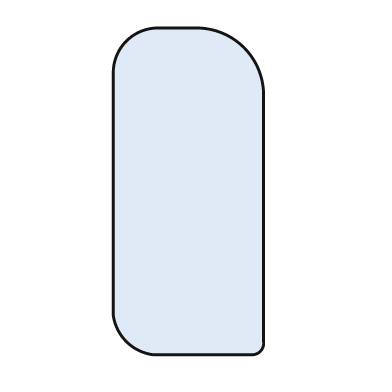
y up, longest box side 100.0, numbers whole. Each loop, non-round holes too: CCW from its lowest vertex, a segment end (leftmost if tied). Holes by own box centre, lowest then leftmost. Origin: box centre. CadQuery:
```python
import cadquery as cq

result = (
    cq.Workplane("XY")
    .moveTo(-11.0, -50.0)
    .lineTo(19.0, -50.0)
    .threePointArc((22.0, -49.0), (23.0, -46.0))
    .lineTo(23.0, 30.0)
    .threePointArc((17.0, 44.0), (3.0, 50.0))
    .lineTo(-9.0, 50.0)
    .threePointArc((-19.0, 46.0), (-23.0, 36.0))
    .lineTo(-23.0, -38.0)
    .threePointArc((-19.0, -46.0), (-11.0, -50.0))
    .close()
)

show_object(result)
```